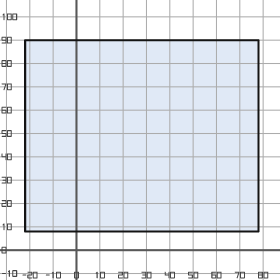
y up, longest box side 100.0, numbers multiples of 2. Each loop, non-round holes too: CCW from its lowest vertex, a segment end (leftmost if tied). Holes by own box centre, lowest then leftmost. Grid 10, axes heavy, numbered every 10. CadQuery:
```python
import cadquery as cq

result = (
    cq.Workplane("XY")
    .moveTo(-22.0, 8.0)
    .lineTo(78.0, 8.0)
    .lineTo(78.0, 90.0)
    .lineTo(-22.0, 90.0)
    .close()
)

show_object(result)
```